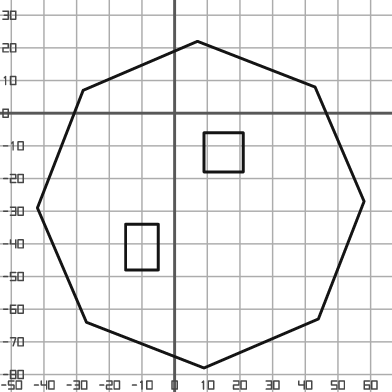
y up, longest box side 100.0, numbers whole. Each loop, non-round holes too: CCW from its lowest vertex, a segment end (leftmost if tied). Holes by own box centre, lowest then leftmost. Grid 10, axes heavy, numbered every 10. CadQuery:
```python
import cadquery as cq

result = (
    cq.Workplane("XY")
    .moveTo(9.0, -78.0)
    .lineTo(44.0, -63.0)
    .lineTo(58.0, -27.0)
    .lineTo(43.0, 8.0)
    .lineTo(7.0, 22.0)
    .lineTo(-28.0, 7.0)
    .lineTo(-42.0, -29.0)
    .lineTo(-27.0, -64.0)
    .close()
    .moveTo(-15.0, -48.0)
    .lineTo(-5.0, -48.0)
    .lineTo(-5.0, -34.0)
    .lineTo(-15.0, -34.0)
    .close()
    .moveTo(9.0, -18.0)
    .lineTo(21.0, -18.0)
    .lineTo(21.0, -6.0)
    .lineTo(9.0, -6.0)
    .close()
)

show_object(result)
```